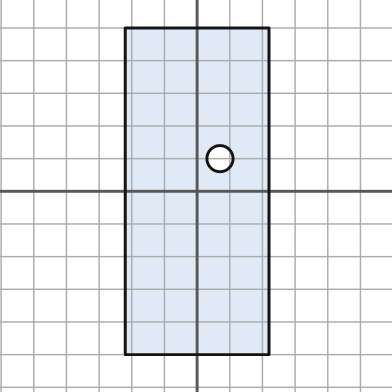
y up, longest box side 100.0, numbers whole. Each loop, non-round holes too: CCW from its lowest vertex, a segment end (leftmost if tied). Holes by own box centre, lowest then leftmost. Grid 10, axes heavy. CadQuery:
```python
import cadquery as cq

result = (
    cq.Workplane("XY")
    .moveTo(-22.0, -50.0)
    .lineTo(22.0, -50.0)
    .lineTo(22.0, 50.0)
    .lineTo(-22.0, 50.0)
    .close()
    .moveTo(7.0, 10.0)
    .circle(4.0)
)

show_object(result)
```